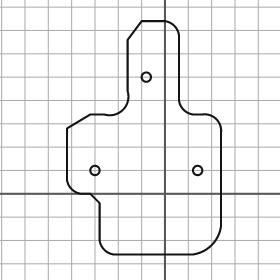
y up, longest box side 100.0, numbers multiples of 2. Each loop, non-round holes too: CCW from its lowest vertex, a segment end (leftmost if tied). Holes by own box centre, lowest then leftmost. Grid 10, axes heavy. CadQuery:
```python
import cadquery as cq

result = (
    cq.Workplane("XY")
    .moveTo(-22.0, -26.0)
    .lineTo(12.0, -26.0)
    .threePointArc((20.0, -22.0), (24.0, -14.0))
    .lineTo(24.0, 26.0)
    .threePointArc((22.0, 32.0), (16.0, 34.0))
    .lineTo(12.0, 34.0)
    .threePointArc((8.0, 36.0), (6.0, 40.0))
    .lineTo(6.0, 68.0)
    .threePointArc((4.0, 72.0), (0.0, 74.0))
    .lineTo(-10.0, 74.0)
    .lineTo(-16.0, 66.0)
    .lineTo(-16.0, 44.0)
    .threePointArc((-18.0, 36.0), (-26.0, 34.0))
    .lineTo(-32.0, 34.0)
    .lineTo(-42.0, 28.0)
    .lineTo(-42.0, 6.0)
    .threePointArc((-40.0, 2.0), (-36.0, 0.0))
    .lineTo(-32.0, 0.0)
    .lineTo(-28.0, -4.0)
    .lineTo(-28.0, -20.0)
    .threePointArc((-26.0, -24.0), (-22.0, -26.0))
    .close()
    .moveTo(-30.0, 10.0)
    .circle(2.0)
    .moveTo(14.0, 10.0)
    .circle(2.0)
    .moveTo(-8.0, 50.0)
    .circle(2.0)
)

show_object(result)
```